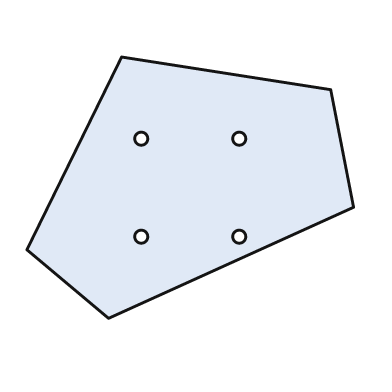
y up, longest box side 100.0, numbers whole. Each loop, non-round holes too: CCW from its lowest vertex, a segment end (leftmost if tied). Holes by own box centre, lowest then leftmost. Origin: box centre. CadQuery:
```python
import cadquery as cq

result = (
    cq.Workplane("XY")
    .moveTo(-25.0, -40.0)
    .lineTo(50.0, -6.0)
    .lineTo(43.0, 30.0)
    .lineTo(-21.0, 40.0)
    .lineTo(-50.0, -19.0)
    .close()
    .moveTo(-15.0, -15.0)
    .circle(2.0)
    .moveTo(15.0, -15.0)
    .circle(2.0)
    .moveTo(-15.0, 15.0)
    .circle(2.0)
    .moveTo(15.0, 15.0)
    .circle(2.0)
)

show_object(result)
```